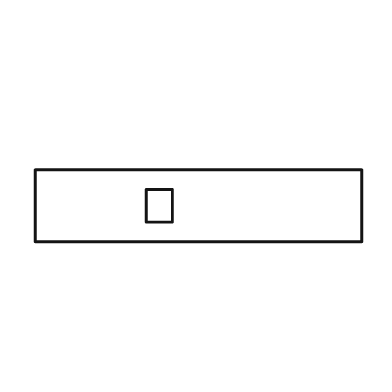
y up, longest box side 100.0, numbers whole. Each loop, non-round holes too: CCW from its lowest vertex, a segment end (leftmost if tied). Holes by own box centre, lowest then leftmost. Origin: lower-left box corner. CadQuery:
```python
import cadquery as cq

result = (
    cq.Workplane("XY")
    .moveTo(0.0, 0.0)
    .lineTo(100.0, 0.0)
    .lineTo(100.0, 22.0)
    .lineTo(0.0, 22.0)
    .close()
    .moveTo(34.0, 6.0)
    .lineTo(42.0, 6.0)
    .lineTo(42.0, 16.0)
    .lineTo(34.0, 16.0)
    .close()
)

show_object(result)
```